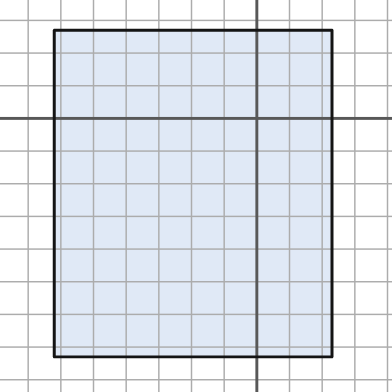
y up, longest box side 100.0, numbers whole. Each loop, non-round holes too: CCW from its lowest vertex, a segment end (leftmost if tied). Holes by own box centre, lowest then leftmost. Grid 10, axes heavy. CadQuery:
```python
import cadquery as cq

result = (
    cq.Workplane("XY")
    .moveTo(-62.0, -73.0)
    .lineTo(23.0, -73.0)
    .lineTo(23.0, 27.0)
    .lineTo(-62.0, 27.0)
    .close()
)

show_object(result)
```